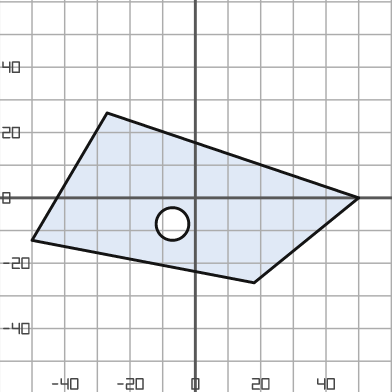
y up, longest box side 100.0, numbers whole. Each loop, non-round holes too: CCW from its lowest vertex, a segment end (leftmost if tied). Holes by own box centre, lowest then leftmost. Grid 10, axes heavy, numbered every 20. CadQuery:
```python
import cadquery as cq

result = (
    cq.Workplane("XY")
    .moveTo(18.0, -26.0)
    .lineTo(50.0, 0.0)
    .lineTo(-27.0, 26.0)
    .lineTo(-50.0, -13.0)
    .close()
    .moveTo(-7.0, -8.0)
    .circle(5.0)
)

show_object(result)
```